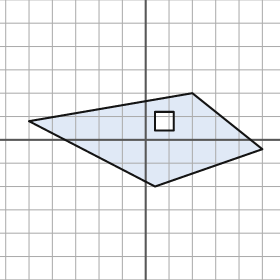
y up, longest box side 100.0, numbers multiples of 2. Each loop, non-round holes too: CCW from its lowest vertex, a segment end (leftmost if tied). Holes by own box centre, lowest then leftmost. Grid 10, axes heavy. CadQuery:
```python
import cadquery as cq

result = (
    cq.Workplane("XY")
    .moveTo(4.0, -20.0)
    .lineTo(50.0, -4.0)
    .lineTo(20.0, 20.0)
    .lineTo(-50.0, 8.0)
    .close()
    .moveTo(4.0, 4.0)
    .lineTo(12.0, 4.0)
    .lineTo(12.0, 12.0)
    .lineTo(4.0, 12.0)
    .close()
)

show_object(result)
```